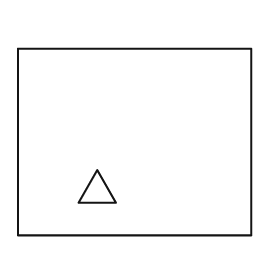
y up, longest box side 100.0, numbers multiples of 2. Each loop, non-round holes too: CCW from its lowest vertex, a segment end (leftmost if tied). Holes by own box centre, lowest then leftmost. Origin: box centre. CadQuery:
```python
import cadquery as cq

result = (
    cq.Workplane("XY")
    .moveTo(-50.0, -40.0)
    .lineTo(50.0, -40.0)
    .lineTo(50.0, 40.0)
    .lineTo(-50.0, 40.0)
    .close()
    .moveTo(-24.0, -26.0)
    .lineTo(-8.0, -26.0)
    .lineTo(-16.0, -12.0)
    .close()
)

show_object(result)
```